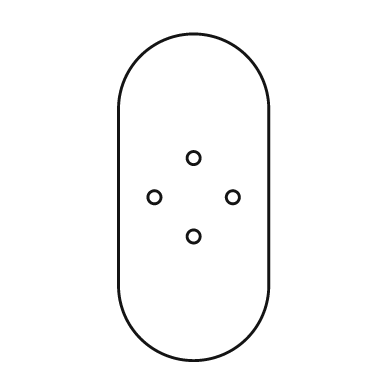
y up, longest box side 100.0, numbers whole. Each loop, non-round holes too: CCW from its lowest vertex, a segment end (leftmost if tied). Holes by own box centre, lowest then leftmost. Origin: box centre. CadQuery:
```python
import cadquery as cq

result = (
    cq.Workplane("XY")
    .moveTo(-23.0, -27.0)
    .threePointArc((0.0, -50.0), (23.0, -27.0))
    .lineTo(23.0, 27.0)
    .threePointArc((0.0, 50.0), (-23.0, 27.0))
    .close()
    .moveTo(0.0, -12.0)
    .circle(2.0)
    .moveTo(-12.0, 0.0)
    .circle(2.0)
    .moveTo(12.0, 0.0)
    .circle(2.0)
    .moveTo(0.0, 12.0)
    .circle(2.0)
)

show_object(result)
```